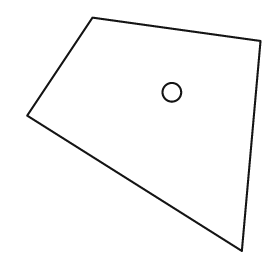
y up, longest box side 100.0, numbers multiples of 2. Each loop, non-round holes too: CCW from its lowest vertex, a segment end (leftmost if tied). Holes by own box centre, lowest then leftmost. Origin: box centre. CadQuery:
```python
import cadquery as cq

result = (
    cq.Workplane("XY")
    .moveTo(42.0, -50.0)
    .lineTo(50.0, 40.0)
    .lineTo(-22.0, 50.0)
    .lineTo(-50.0, 8.0)
    .close()
    .moveTo(12.0, 18.0)
    .circle(4.0)
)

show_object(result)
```